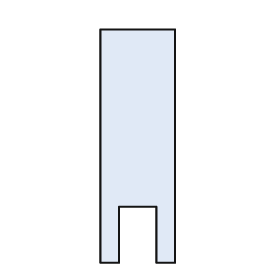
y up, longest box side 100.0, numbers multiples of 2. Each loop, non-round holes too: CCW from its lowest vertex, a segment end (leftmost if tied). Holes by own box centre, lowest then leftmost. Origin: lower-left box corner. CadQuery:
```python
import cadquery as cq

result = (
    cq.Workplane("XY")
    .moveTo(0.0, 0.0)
    .lineTo(8.0, 0.0)
    .lineTo(8.0, 24.0)
    .lineTo(24.0, 24.0)
    .lineTo(24.0, 0.0)
    .lineTo(32.0, 0.0)
    .lineTo(32.0, 100.0)
    .lineTo(0.0, 100.0)
    .close()
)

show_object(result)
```